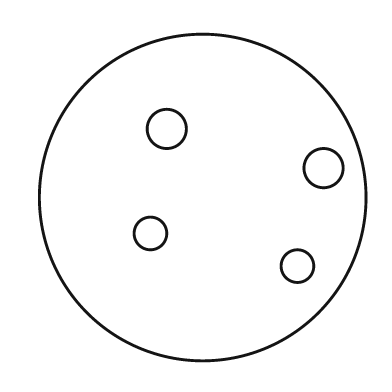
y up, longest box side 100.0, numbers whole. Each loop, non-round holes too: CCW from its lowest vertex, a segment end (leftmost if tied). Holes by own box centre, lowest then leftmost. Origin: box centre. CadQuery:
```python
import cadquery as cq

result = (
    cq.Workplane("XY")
    .moveTo(0.0, 0.0)
    .circle(50.0)
    .moveTo(29.0, -21.0)
    .circle(5.0)
    .moveTo(-16.0, -11.0)
    .circle(5.0)
    .moveTo(37.0, 9.0)
    .circle(6.0)
    .moveTo(-11.0, 21.0)
    .circle(6.0)
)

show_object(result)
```